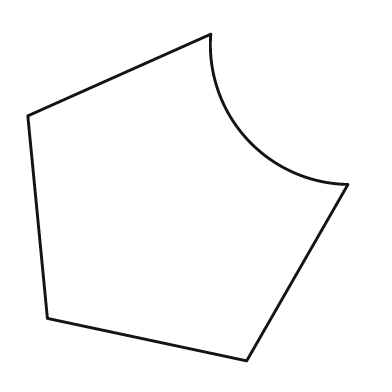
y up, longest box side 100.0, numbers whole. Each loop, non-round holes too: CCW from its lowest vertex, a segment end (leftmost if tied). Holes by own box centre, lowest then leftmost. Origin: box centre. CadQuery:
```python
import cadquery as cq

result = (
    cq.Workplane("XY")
    .moveTo(18.0, -50.0)
    .lineTo(49.0, 4.0)
    .threePointArc((18.0, 18.0), (7.0, 50.0))
    .lineTo(-49.0, 25.0)
    .lineTo(-43.0, -37.0)
    .close()
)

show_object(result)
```